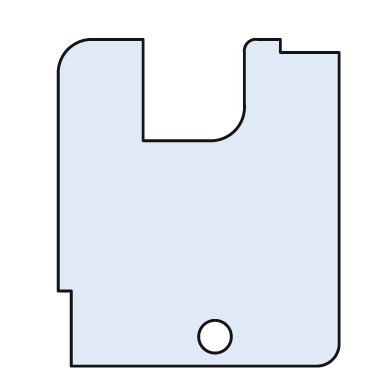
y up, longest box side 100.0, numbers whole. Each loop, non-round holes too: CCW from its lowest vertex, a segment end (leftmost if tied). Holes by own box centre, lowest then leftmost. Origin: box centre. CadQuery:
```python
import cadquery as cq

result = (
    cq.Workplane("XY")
    .moveTo(-39.0, -50.0)
    .lineTo(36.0, -50.0)
    .threePointArc((41.0, -48.0), (43.0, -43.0))
    .lineTo(43.0, 46.0)
    .lineTo(25.0, 46.0)
    .lineTo(25.0, 50.0)
    .lineTo(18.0, 50.0)
    .threePointArc((15.0, 49.0), (14.0, 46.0))
    .lineTo(14.0, 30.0)
    .threePointArc((11.0, 22.0), (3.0, 19.0))
    .lineTo(-17.0, 19.0)
    .lineTo(-17.0, 50.0)
    .lineTo(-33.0, 50.0)
    .threePointArc((-40.0, 47.0), (-43.0, 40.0))
    .lineTo(-43.0, -27.0)
    .lineTo(-39.0, -27.0)
    .close()
    .moveTo(5.0, -41.0)
    .circle(5.0)
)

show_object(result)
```